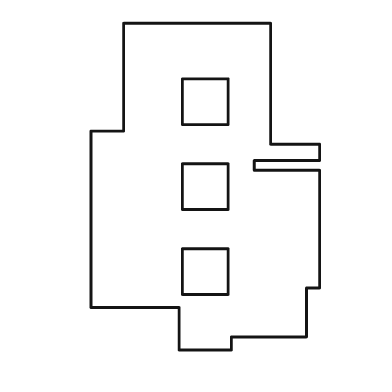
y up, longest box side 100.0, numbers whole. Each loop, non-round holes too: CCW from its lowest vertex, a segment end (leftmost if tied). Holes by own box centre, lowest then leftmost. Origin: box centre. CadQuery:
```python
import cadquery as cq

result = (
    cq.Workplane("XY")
    .moveTo(-8.0, -50.0)
    .lineTo(8.0, -50.0)
    .lineTo(8.0, -46.0)
    .lineTo(31.0, -46.0)
    .lineTo(31.0, -31.0)
    .lineTo(35.0, -31.0)
    .lineTo(35.0, 5.0)
    .lineTo(15.0, 5.0)
    .lineTo(15.0, 8.0)
    .lineTo(35.0, 8.0)
    .lineTo(35.0, 13.0)
    .lineTo(20.0, 13.0)
    .lineTo(20.0, 50.0)
    .lineTo(-25.0, 50.0)
    .lineTo(-25.0, 17.0)
    .lineTo(-35.0, 17.0)
    .lineTo(-35.0, -37.0)
    .lineTo(-8.0, -37.0)
    .close()
    .moveTo(-7.0, -33.0)
    .lineTo(7.0, -33.0)
    .lineTo(7.0, -19.0)
    .lineTo(-7.0, -19.0)
    .close()
    .moveTo(-7.0, -7.0)
    .lineTo(7.0, -7.0)
    .lineTo(7.0, 7.0)
    .lineTo(-7.0, 7.0)
    .close()
    .moveTo(-7.0, 19.0)
    .lineTo(7.0, 19.0)
    .lineTo(7.0, 33.0)
    .lineTo(-7.0, 33.0)
    .close()
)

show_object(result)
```